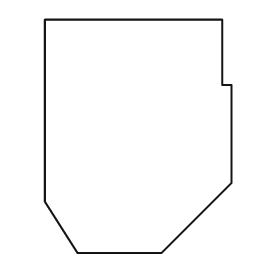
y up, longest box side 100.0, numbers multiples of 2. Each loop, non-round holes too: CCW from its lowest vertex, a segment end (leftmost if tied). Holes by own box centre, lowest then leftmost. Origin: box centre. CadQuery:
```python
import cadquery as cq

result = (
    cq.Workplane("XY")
    .moveTo(-26.0, -50.0)
    .lineTo(10.0, -50.0)
    .lineTo(40.0, -20.0)
    .lineTo(40.0, 22.0)
    .lineTo(36.0, 22.0)
    .lineTo(36.0, 50.0)
    .lineTo(-40.0, 50.0)
    .lineTo(-40.0, -28.0)
    .close()
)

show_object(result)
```